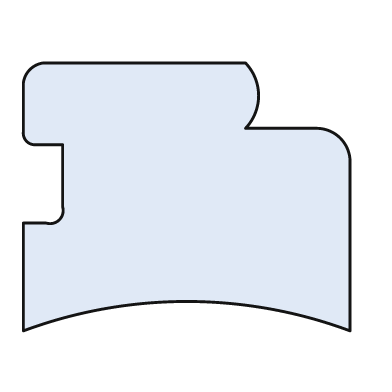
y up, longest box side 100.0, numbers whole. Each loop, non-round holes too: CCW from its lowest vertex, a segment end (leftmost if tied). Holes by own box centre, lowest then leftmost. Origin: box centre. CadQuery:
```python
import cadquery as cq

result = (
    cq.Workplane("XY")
    .moveTo(-50.0, -41.0)
    .threePointArc((0.0, -32.0), (50.0, -41.0))
    .lineTo(50.0, 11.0)
    .threePointArc((47.0, 18.0), (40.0, 21.0))
    .lineTo(18.0, 21.0)
    .threePointArc((22.0, 31.0), (18.0, 41.0))
    .lineTo(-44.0, 41.0)
    .threePointArc((-48.0, 39.0), (-50.0, 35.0))
    .lineTo(-50.0, 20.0)
    .threePointArc((-49.0, 17.0), (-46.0, 16.0))
    .lineTo(-38.0, 16.0)
    .lineTo(-38.0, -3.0)
    .threePointArc((-39.0, -7.0), (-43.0, -8.0))
    .lineTo(-50.0, -8.0)
    .close()
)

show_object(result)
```